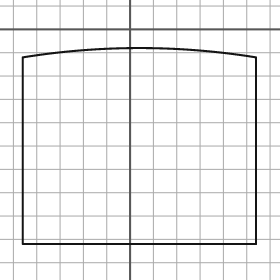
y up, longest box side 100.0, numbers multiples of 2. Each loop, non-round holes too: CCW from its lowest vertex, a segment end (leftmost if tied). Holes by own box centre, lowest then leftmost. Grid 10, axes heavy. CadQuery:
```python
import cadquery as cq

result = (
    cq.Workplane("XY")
    .moveTo(-46.0, -92.0)
    .lineTo(54.0, -92.0)
    .lineTo(54.0, -12.0)
    .threePointArc((4.0, -8.0), (-46.0, -12.0))
    .close()
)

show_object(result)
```